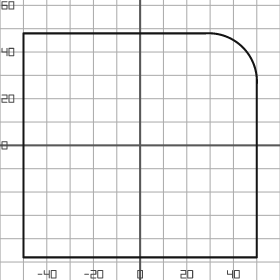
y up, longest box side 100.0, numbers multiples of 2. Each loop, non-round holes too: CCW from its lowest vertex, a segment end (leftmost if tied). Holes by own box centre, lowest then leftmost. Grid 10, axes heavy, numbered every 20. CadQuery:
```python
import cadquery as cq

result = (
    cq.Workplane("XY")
    .moveTo(-50.0, -48.0)
    .lineTo(50.0, -48.0)
    .lineTo(50.0, 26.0)
    .threePointArc((44.0, 42.0), (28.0, 48.0))
    .lineTo(-50.0, 48.0)
    .close()
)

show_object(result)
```